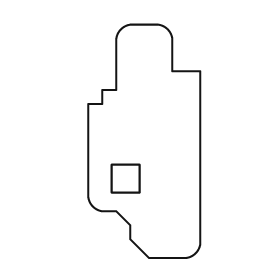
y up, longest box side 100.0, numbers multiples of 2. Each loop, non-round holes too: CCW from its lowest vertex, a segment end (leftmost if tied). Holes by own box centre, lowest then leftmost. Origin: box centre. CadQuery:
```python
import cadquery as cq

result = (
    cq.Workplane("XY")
    .moveTo(2.0, -50.0)
    .lineTo(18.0, -50.0)
    .threePointArc((22.0, -48.0), (24.0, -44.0))
    .lineTo(24.0, 30.0)
    .lineTo(12.0, 30.0)
    .lineTo(12.0, 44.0)
    .threePointArc((10.0, 48.0), (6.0, 50.0))
    .lineTo(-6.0, 50.0)
    .threePointArc((-10.0, 48.0), (-12.0, 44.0))
    .lineTo(-12.0, 22.0)
    .lineTo(-18.0, 22.0)
    .lineTo(-18.0, 16.0)
    .lineTo(-24.0, 16.0)
    .lineTo(-24.0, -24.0)
    .threePointArc((-22.0, -28.0), (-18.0, -30.0))
    .lineTo(-12.0, -30.0)
    .lineTo(-6.0, -36.0)
    .lineTo(-6.0, -42.0)
    .close()
    .moveTo(-14.0, -22.0)
    .lineTo(-2.0, -22.0)
    .lineTo(-2.0, -10.0)
    .lineTo(-14.0, -10.0)
    .close()
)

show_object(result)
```